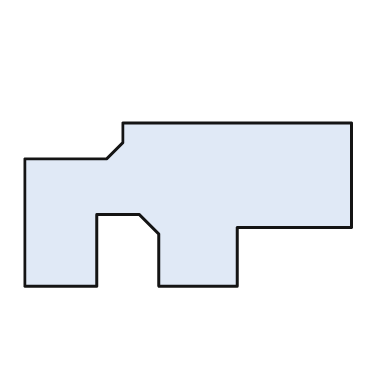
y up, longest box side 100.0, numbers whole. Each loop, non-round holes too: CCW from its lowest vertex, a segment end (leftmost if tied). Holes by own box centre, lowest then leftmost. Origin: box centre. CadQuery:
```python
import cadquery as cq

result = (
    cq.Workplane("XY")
    .moveTo(-50.0, -25.0)
    .lineTo(-28.0, -25.0)
    .lineTo(-28.0, -3.0)
    .lineTo(-15.0, -3.0)
    .lineTo(-9.0, -9.0)
    .lineTo(-9.0, -25.0)
    .lineTo(15.0, -25.0)
    .lineTo(15.0, -7.0)
    .lineTo(50.0, -7.0)
    .lineTo(50.0, 25.0)
    .lineTo(-20.0, 25.0)
    .lineTo(-20.0, 19.0)
    .lineTo(-25.0, 14.0)
    .lineTo(-50.0, 14.0)
    .close()
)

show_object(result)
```